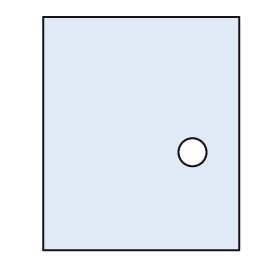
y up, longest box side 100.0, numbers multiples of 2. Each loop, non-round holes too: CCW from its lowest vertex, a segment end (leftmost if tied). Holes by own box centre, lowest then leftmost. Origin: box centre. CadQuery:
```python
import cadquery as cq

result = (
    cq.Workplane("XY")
    .moveTo(-42.0, -50.0)
    .lineTo(42.0, -50.0)
    .lineTo(42.0, 50.0)
    .lineTo(-42.0, 50.0)
    .close()
    .moveTo(22.0, -8.0)
    .circle(6.0)
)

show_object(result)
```